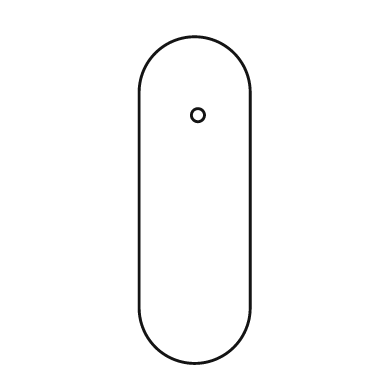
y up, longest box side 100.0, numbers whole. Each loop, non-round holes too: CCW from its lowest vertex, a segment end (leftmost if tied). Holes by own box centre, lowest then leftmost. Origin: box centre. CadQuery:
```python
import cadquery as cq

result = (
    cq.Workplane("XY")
    .moveTo(-17.0, -33.0)
    .threePointArc((0.0, -50.0), (17.0, -33.0))
    .lineTo(17.0, 33.0)
    .threePointArc((0.0, 50.0), (-17.0, 33.0))
    .close()
    .moveTo(1.0, 26.0)
    .circle(2.0)
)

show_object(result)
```